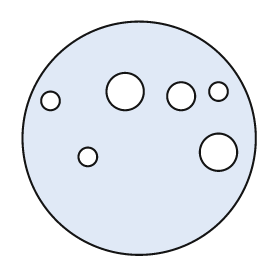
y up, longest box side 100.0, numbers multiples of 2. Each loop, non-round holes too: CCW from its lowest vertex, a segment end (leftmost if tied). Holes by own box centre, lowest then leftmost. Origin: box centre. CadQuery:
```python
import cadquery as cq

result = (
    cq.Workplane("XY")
    .moveTo(0.0, 0.0)
    .circle(50.0)
    .moveTo(-22.0, -8.0)
    .circle(4.0)
    .moveTo(34.0, -6.0)
    .circle(8.0)
    .moveTo(-38.0, 16.0)
    .circle(4.0)
    .moveTo(18.0, 18.0)
    .circle(6.0)
    .moveTo(-6.0, 20.0)
    .circle(8.0)
    .moveTo(34.0, 20.0)
    .circle(4.0)
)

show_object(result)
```